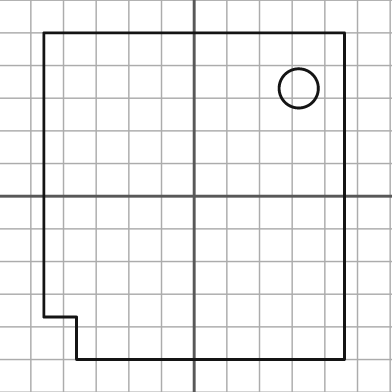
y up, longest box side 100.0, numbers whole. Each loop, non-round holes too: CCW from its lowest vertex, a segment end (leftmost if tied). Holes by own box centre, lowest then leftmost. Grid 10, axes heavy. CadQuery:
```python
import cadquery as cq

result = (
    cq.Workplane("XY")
    .moveTo(-36.0, -50.0)
    .lineTo(46.0, -50.0)
    .lineTo(46.0, 50.0)
    .lineTo(-46.0, 50.0)
    .lineTo(-46.0, -37.0)
    .lineTo(-36.0, -37.0)
    .close()
    .moveTo(32.0, 33.0)
    .circle(6.0)
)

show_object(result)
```